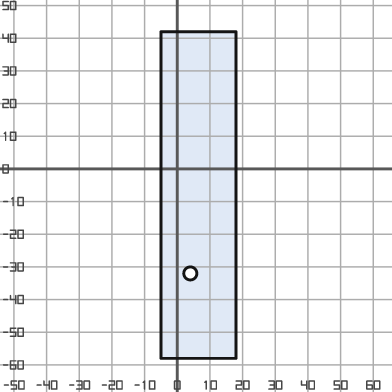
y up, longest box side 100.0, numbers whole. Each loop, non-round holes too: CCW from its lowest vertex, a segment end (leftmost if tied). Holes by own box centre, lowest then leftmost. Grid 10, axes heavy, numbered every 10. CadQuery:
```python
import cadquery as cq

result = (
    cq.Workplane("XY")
    .moveTo(-5.0, -58.0)
    .lineTo(18.0, -58.0)
    .lineTo(18.0, 42.0)
    .lineTo(-5.0, 42.0)
    .close()
    .moveTo(4.0, -32.0)
    .circle(2.0)
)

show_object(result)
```